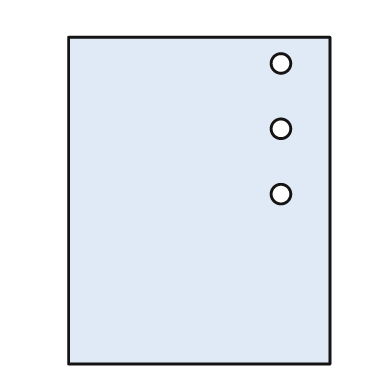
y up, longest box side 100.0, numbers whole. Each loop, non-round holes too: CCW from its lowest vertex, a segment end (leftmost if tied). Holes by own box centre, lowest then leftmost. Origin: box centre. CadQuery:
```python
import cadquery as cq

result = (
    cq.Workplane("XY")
    .moveTo(-40.0, -50.0)
    .lineTo(40.0, -50.0)
    .lineTo(40.0, 50.0)
    .lineTo(-40.0, 50.0)
    .close()
    .moveTo(25.0, 2.0)
    .circle(3.0)
    .moveTo(25.0, 22.0)
    .circle(3.0)
    .moveTo(25.0, 42.0)
    .circle(3.0)
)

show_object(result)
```